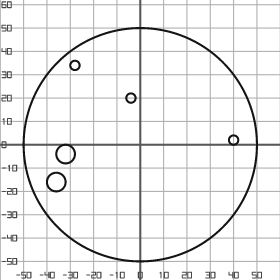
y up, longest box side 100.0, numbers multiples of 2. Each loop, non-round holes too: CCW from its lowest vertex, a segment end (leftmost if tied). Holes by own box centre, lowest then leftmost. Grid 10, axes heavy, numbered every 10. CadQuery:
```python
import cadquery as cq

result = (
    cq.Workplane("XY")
    .moveTo(0.0, 0.0)
    .circle(50.0)
    .moveTo(-36.0, -16.0)
    .circle(4.0)
    .moveTo(-32.0, -4.0)
    .circle(4.0)
    .moveTo(40.0, 2.0)
    .circle(2.0)
    .moveTo(-4.0, 20.0)
    .circle(2.0)
    .moveTo(-28.0, 34.0)
    .circle(2.0)
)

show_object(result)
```